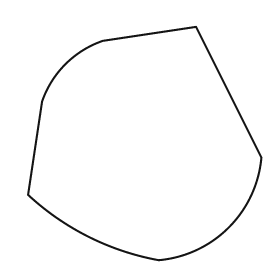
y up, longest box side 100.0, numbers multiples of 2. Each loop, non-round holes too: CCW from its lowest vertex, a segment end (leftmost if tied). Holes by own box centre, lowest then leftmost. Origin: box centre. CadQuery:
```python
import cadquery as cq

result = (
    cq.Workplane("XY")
    .moveTo(6.0, -50.0)
    .threePointArc((36.0, -36.0), (50.0, -6.0))
    .lineTo(22.0, 50.0)
    .lineTo(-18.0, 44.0)
    .threePointArc((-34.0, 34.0), (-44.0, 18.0))
    .lineTo(-50.0, -22.0)
    .threePointArc((-24.0, -40.0), (6.0, -50.0))
    .close()
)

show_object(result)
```